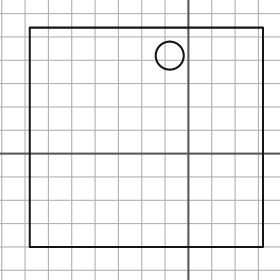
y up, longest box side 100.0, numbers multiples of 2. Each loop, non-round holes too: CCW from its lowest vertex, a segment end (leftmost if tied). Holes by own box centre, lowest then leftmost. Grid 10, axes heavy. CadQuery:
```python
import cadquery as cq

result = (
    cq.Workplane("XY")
    .moveTo(-68.0, -40.0)
    .lineTo(32.0, -40.0)
    .lineTo(32.0, 54.0)
    .lineTo(-68.0, 54.0)
    .close()
    .moveTo(-8.0, 42.0)
    .circle(6.0)
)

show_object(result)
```